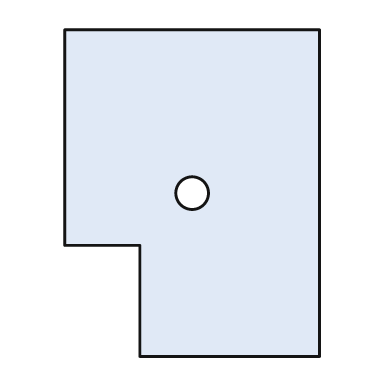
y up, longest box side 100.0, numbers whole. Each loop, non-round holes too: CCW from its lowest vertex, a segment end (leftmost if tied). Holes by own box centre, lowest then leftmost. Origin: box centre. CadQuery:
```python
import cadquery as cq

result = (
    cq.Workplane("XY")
    .moveTo(-16.0, -50.0)
    .lineTo(39.0, -50.0)
    .lineTo(39.0, 50.0)
    .lineTo(-39.0, 50.0)
    .lineTo(-39.0, -16.0)
    .lineTo(-16.0, -16.0)
    .close()
    .moveTo(0.0, 0.0)
    .circle(5.0)
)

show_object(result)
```